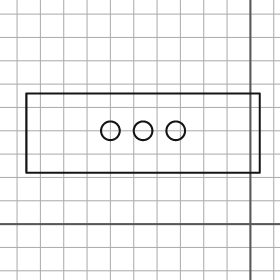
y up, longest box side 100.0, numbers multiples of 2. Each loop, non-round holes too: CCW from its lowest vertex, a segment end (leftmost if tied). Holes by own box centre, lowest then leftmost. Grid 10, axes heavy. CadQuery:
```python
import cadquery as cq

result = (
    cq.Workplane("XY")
    .moveTo(-96.0, 22.0)
    .lineTo(4.0, 22.0)
    .lineTo(4.0, 56.0)
    .lineTo(-96.0, 56.0)
    .close()
    .moveTo(-60.0, 40.0)
    .circle(4.0)
    .moveTo(-46.0, 40.0)
    .circle(4.0)
    .moveTo(-32.0, 40.0)
    .circle(4.0)
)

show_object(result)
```